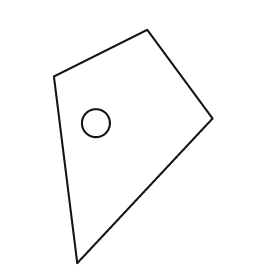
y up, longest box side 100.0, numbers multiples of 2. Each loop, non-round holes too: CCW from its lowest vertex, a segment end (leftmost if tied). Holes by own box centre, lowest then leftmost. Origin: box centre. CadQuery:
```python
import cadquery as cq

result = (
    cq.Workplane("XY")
    .moveTo(-24.0, -50.0)
    .lineTo(34.0, 12.0)
    .lineTo(6.0, 50.0)
    .lineTo(-34.0, 30.0)
    .close()
    .moveTo(-16.0, 10.0)
    .circle(6.0)
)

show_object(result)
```